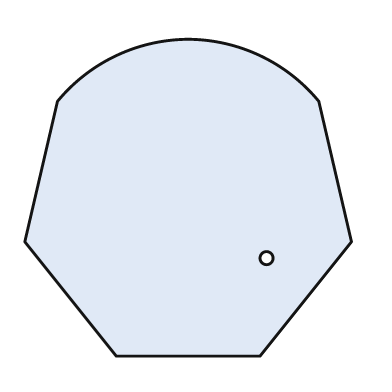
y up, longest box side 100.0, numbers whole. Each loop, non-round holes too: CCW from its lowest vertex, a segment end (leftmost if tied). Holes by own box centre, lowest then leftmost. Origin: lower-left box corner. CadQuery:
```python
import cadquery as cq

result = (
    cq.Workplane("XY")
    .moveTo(28.0, 0.0)
    .lineTo(72.0, 0.0)
    .lineTo(100.0, 35.0)
    .lineTo(90.0, 78.0)
    .threePointArc((72.0, 92.0), (50.0, 97.0))
    .threePointArc((28.0, 92.0), (10.0, 78.0))
    .lineTo(0.0, 35.0)
    .close()
    .moveTo(74.0, 30.0)
    .circle(2.0)
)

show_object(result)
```